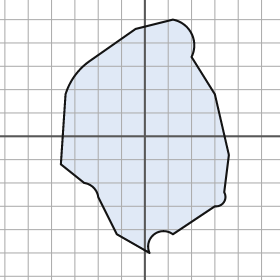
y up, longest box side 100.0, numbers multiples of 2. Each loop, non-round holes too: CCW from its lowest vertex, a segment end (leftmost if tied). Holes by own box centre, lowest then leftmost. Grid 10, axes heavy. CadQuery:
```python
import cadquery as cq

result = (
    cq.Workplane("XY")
    .moveTo(2.0, -50.0)
    .threePointArc((4.0, -42.0), (12.0, -42.0))
    .lineTo(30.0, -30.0)
    .threePointArc((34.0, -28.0), (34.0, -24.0))
    .lineTo(36.0, -8.0)
    .lineTo(30.0, 18.0)
    .lineTo(20.0, 34.0)
    .threePointArc((20.0, 44.0), (12.0, 50.0))
    .lineTo(-4.0, 46.0)
    .lineTo(-24.0, 32.0)
    .threePointArc((-30.0, 26.0), (-34.0, 18.0))
    .lineTo(-36.0, -12.0)
    .lineTo(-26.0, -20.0)
    .threePointArc((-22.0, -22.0), (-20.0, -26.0))
    .lineTo(-12.0, -42.0)
    .close()
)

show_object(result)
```